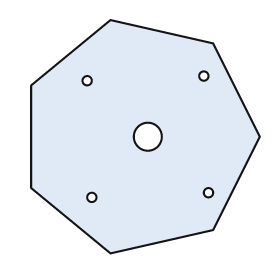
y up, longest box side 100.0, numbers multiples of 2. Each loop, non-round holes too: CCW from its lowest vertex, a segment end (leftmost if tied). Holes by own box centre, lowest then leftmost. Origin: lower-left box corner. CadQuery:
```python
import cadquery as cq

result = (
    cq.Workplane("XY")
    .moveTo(34.0, 0.0)
    .lineTo(78.0, 10.0)
    .lineTo(98.0, 50.0)
    .lineTo(78.0, 90.0)
    .lineTo(34.0, 100.0)
    .lineTo(0.0, 72.0)
    .lineTo(0.0, 28.0)
    .close()
    .moveTo(26.0, 24.0)
    .circle(2.0)
    .moveTo(76.0, 26.0)
    .circle(2.0)
    .moveTo(50.0, 50.0)
    .circle(6.0)
    .moveTo(24.0, 74.0)
    .circle(2.0)
    .moveTo(74.0, 76.0)
    .circle(2.0)
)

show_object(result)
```